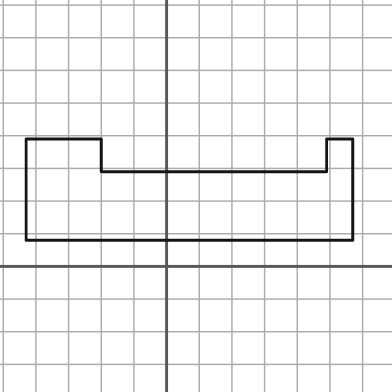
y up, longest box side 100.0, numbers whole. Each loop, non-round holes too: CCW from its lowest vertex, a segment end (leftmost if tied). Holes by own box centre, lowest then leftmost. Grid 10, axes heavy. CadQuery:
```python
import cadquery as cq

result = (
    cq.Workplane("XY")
    .moveTo(-43.0, 8.0)
    .lineTo(57.0, 8.0)
    .lineTo(57.0, 39.0)
    .lineTo(49.0, 39.0)
    .lineTo(49.0, 29.0)
    .lineTo(-20.0, 29.0)
    .lineTo(-20.0, 39.0)
    .lineTo(-43.0, 39.0)
    .close()
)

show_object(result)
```